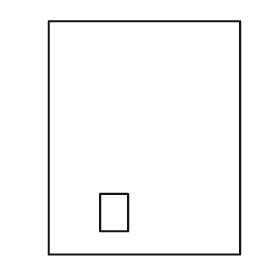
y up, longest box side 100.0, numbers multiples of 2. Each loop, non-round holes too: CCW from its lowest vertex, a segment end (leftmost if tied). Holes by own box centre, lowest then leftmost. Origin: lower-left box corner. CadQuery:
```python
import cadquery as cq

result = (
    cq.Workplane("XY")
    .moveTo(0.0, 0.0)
    .lineTo(82.0, 0.0)
    .lineTo(82.0, 100.0)
    .lineTo(0.0, 100.0)
    .close()
    .moveTo(22.0, 10.0)
    .lineTo(34.0, 10.0)
    .lineTo(34.0, 26.0)
    .lineTo(22.0, 26.0)
    .close()
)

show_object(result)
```